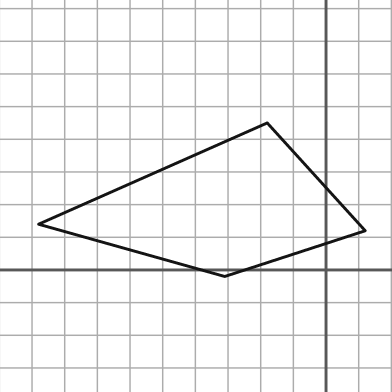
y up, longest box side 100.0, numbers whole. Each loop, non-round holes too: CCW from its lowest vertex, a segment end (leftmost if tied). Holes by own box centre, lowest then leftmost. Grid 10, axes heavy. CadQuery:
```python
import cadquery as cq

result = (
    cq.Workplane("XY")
    .moveTo(-31.0, -2.0)
    .lineTo(12.0, 12.0)
    .lineTo(-18.0, 45.0)
    .lineTo(-88.0, 14.0)
    .close()
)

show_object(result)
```